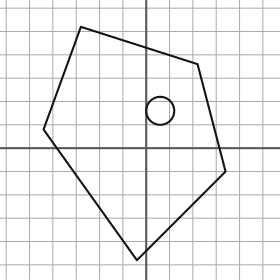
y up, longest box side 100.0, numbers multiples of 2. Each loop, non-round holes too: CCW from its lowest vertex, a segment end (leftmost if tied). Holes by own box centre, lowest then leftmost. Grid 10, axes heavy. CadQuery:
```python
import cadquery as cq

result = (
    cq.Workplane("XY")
    .moveTo(-4.0, -48.0)
    .lineTo(34.0, -10.0)
    .lineTo(22.0, 36.0)
    .lineTo(-28.0, 52.0)
    .lineTo(-44.0, 8.0)
    .close()
    .moveTo(6.0, 16.0)
    .circle(6.0)
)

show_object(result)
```